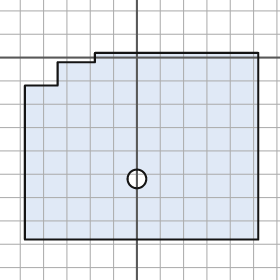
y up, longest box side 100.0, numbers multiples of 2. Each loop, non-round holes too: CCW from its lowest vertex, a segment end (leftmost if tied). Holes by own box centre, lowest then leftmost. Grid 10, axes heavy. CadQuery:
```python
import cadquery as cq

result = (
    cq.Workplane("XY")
    .moveTo(-48.0, -78.0)
    .lineTo(52.0, -78.0)
    .lineTo(52.0, 2.0)
    .lineTo(-18.0, 2.0)
    .lineTo(-18.0, -2.0)
    .lineTo(-34.0, -2.0)
    .lineTo(-34.0, -12.0)
    .lineTo(-48.0, -12.0)
    .close()
    .moveTo(0.0, -52.0)
    .circle(4.0)
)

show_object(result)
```